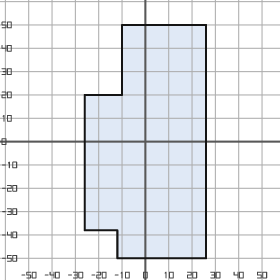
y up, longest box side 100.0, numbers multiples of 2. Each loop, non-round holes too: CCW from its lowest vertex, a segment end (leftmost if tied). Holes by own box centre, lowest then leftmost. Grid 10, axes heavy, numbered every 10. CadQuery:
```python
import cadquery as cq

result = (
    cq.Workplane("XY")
    .moveTo(-12.0, -50.0)
    .lineTo(26.0, -50.0)
    .lineTo(26.0, 50.0)
    .lineTo(-10.0, 50.0)
    .lineTo(-10.0, 20.0)
    .lineTo(-26.0, 20.0)
    .lineTo(-26.0, -38.0)
    .lineTo(-12.0, -38.0)
    .close()
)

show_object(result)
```